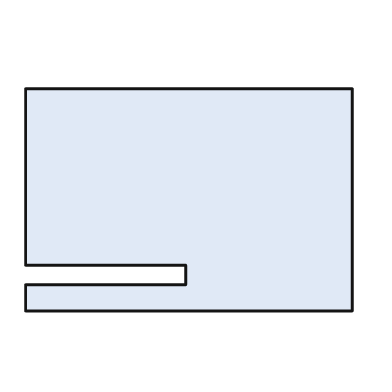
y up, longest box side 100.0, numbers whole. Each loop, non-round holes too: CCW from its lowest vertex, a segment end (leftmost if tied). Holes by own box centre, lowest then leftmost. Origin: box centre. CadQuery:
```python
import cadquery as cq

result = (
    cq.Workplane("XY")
    .moveTo(-50.0, -34.0)
    .lineTo(50.0, -34.0)
    .lineTo(50.0, 34.0)
    .lineTo(-50.0, 34.0)
    .lineTo(-50.0, -20.0)
    .lineTo(-1.0, -20.0)
    .lineTo(-1.0, -26.0)
    .lineTo(-50.0, -26.0)
    .close()
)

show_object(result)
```